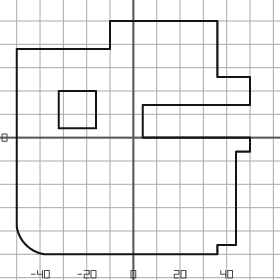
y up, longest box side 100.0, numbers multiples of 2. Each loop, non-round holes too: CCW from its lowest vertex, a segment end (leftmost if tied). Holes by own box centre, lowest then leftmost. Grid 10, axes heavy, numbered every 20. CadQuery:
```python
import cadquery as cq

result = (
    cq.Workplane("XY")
    .moveTo(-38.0, -50.0)
    .lineTo(36.0, -50.0)
    .lineTo(36.0, -46.0)
    .lineTo(44.0, -46.0)
    .lineTo(44.0, -6.0)
    .lineTo(50.0, -6.0)
    .lineTo(50.0, 0.0)
    .lineTo(4.0, 0.0)
    .lineTo(4.0, 14.0)
    .lineTo(50.0, 14.0)
    .lineTo(50.0, 26.0)
    .lineTo(36.0, 26.0)
    .lineTo(36.0, 50.0)
    .lineTo(-10.0, 50.0)
    .lineTo(-10.0, 38.0)
    .lineTo(-50.0, 38.0)
    .lineTo(-50.0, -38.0)
    .threePointArc((-46.0, -46.0), (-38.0, -50.0))
    .close()
    .moveTo(-32.0, 4.0)
    .lineTo(-16.0, 4.0)
    .lineTo(-16.0, 20.0)
    .lineTo(-32.0, 20.0)
    .close()
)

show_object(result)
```